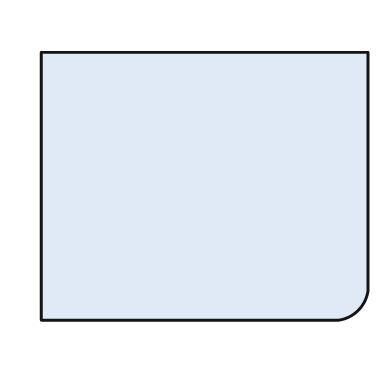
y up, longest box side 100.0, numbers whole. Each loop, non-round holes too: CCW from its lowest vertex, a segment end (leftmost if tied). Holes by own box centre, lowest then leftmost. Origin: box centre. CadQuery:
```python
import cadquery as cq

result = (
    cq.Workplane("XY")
    .moveTo(-50.0, -41.0)
    .lineTo(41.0, -41.0)
    .threePointArc((47.0, -38.0), (50.0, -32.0))
    .lineTo(50.0, 41.0)
    .lineTo(-50.0, 41.0)
    .close()
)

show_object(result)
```